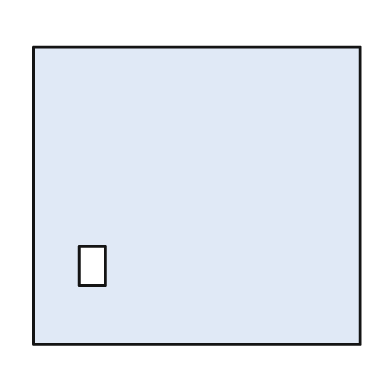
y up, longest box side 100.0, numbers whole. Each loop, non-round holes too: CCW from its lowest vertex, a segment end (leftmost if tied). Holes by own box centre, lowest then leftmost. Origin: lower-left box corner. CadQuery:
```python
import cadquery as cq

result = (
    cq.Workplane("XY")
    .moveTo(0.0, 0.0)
    .lineTo(100.0, 0.0)
    .lineTo(100.0, 91.0)
    .lineTo(0.0, 91.0)
    .close()
    .moveTo(14.0, 18.0)
    .lineTo(22.0, 18.0)
    .lineTo(22.0, 30.0)
    .lineTo(14.0, 30.0)
    .close()
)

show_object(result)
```